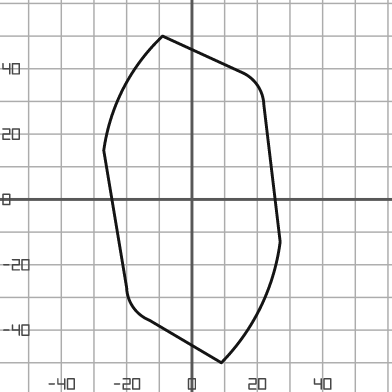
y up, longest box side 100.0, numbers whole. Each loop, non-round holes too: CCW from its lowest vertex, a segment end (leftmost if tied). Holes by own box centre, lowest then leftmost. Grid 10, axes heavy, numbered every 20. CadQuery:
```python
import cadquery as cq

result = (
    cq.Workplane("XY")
    .moveTo(9.0, -50.0)
    .threePointArc((21.0, -33.0), (27.0, -13.0))
    .lineTo(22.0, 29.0)
    .threePointArc((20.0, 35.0), (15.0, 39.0))
    .lineTo(-9.0, 50.0)
    .threePointArc((-21.0, 34.0), (-27.0, 15.0))
    .lineTo(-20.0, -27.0)
    .threePointArc((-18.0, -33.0), (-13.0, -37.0))
    .close()
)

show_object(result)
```